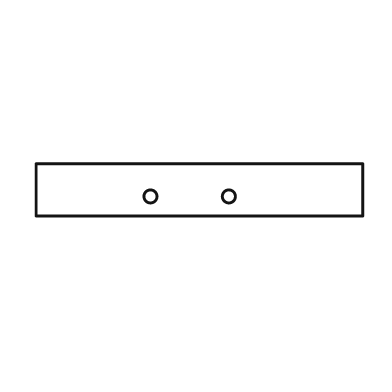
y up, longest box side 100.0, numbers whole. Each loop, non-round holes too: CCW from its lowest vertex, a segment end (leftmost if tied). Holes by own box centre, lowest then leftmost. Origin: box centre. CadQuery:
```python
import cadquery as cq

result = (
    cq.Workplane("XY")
    .moveTo(-50.0, -8.0)
    .lineTo(50.0, -8.0)
    .lineTo(50.0, 8.0)
    .lineTo(-50.0, 8.0)
    .close()
    .moveTo(-15.0, -2.0)
    .circle(2.0)
    .moveTo(9.0, -2.0)
    .circle(2.0)
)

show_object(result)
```